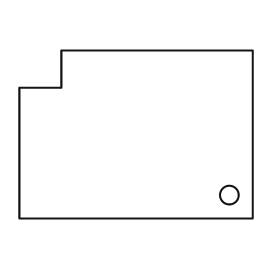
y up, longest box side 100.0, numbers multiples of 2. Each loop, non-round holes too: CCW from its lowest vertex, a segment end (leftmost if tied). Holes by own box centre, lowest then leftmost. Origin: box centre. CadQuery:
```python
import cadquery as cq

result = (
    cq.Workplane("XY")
    .moveTo(-50.0, -36.0)
    .lineTo(50.0, -36.0)
    .lineTo(50.0, 36.0)
    .lineTo(-32.0, 36.0)
    .lineTo(-32.0, 20.0)
    .lineTo(-50.0, 20.0)
    .close()
    .moveTo(40.0, -26.0)
    .circle(4.0)
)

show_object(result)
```